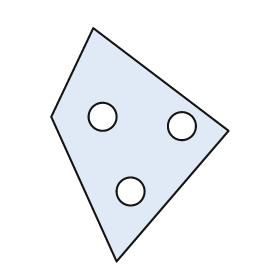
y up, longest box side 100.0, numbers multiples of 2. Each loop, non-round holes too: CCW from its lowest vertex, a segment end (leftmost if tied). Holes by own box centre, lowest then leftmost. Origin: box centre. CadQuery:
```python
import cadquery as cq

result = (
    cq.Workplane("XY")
    .moveTo(-10.0, -50.0)
    .lineTo(38.0, 6.0)
    .lineTo(-20.0, 50.0)
    .lineTo(-38.0, 12.0)
    .close()
    .moveTo(-4.0, -20.0)
    .circle(6.0)
    .moveTo(18.0, 8.0)
    .circle(6.0)
    .moveTo(-16.0, 12.0)
    .circle(6.0)
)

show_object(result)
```